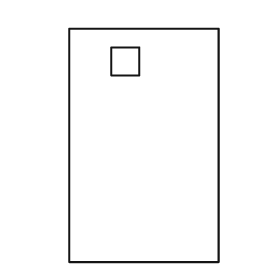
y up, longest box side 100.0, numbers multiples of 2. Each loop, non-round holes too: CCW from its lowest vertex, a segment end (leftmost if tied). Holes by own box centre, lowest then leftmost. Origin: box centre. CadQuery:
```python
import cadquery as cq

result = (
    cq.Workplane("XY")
    .moveTo(-32.0, -50.0)
    .lineTo(32.0, -50.0)
    .lineTo(32.0, 50.0)
    .lineTo(-32.0, 50.0)
    .close()
    .moveTo(-14.0, 30.0)
    .lineTo(-2.0, 30.0)
    .lineTo(-2.0, 42.0)
    .lineTo(-14.0, 42.0)
    .close()
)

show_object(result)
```